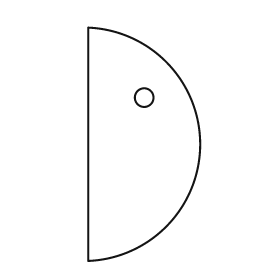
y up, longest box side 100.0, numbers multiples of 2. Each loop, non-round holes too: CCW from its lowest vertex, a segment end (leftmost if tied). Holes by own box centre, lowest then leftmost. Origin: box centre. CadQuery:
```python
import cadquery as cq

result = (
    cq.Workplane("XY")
    .moveTo(-24.0, -50.0)
    .threePointArc((24.0, 0.0), (-24.0, 50.0))
    .close()
    .moveTo(0.0, 20.0)
    .circle(4.0)
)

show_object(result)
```